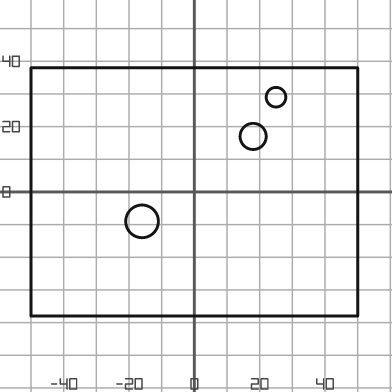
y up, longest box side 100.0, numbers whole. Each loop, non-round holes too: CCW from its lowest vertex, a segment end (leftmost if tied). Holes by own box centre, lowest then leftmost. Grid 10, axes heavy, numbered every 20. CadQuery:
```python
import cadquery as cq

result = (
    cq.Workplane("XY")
    .moveTo(-50.0, -38.0)
    .lineTo(50.0, -38.0)
    .lineTo(50.0, 38.0)
    .lineTo(-50.0, 38.0)
    .close()
    .moveTo(-16.0, -9.0)
    .circle(5.0)
    .moveTo(18.0, 17.0)
    .circle(4.0)
    .moveTo(25.0, 29.0)
    .circle(3.0)
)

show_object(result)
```